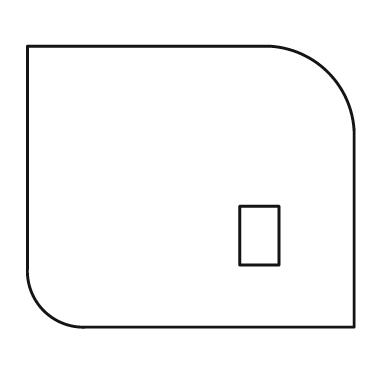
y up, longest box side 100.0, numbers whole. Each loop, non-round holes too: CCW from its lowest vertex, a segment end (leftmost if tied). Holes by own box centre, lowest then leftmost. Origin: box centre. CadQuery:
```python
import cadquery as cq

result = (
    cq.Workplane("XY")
    .moveTo(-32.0, -43.0)
    .lineTo(50.0, -43.0)
    .lineTo(50.0, 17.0)
    .threePointArc((42.0, 35.0), (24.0, 43.0))
    .lineTo(-50.0, 43.0)
    .lineTo(-50.0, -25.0)
    .threePointArc((-45.0, -38.0), (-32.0, -43.0))
    .close()
    .moveTo(15.0, -24.0)
    .lineTo(27.0, -24.0)
    .lineTo(27.0, -6.0)
    .lineTo(15.0, -6.0)
    .close()
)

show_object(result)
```